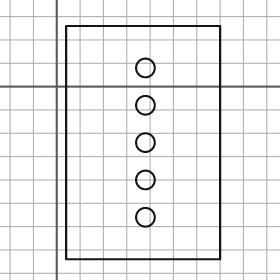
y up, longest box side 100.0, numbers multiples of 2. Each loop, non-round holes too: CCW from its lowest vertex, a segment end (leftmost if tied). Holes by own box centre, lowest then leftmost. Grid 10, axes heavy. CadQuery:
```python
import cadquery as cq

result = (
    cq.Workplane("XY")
    .moveTo(4.0, -74.0)
    .lineTo(70.0, -74.0)
    .lineTo(70.0, 26.0)
    .lineTo(4.0, 26.0)
    .close()
    .moveTo(38.0, -56.0)
    .circle(4.0)
    .moveTo(38.0, -40.0)
    .circle(4.0)
    .moveTo(38.0, -24.0)
    .circle(4.0)
    .moveTo(38.0, -8.0)
    .circle(4.0)
    .moveTo(38.0, 8.0)
    .circle(4.0)
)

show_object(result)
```